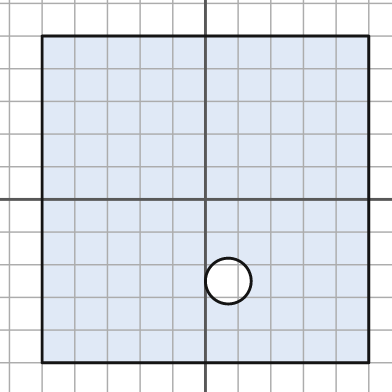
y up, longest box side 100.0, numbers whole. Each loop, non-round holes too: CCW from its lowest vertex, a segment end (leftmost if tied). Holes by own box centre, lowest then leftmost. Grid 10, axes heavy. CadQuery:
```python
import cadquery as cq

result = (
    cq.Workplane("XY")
    .moveTo(-50.0, -50.0)
    .lineTo(50.0, -50.0)
    .lineTo(50.0, 50.0)
    .lineTo(-50.0, 50.0)
    .close()
    .moveTo(7.0, -25.0)
    .circle(7.0)
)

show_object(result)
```